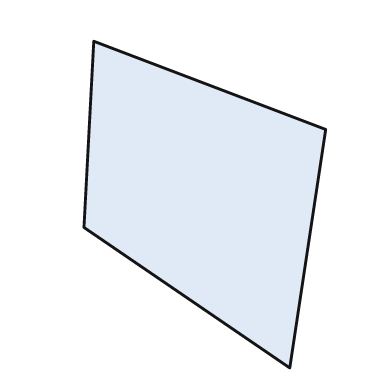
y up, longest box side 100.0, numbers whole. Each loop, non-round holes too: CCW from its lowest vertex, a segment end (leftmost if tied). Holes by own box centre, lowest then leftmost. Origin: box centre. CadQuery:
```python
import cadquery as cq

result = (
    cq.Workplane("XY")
    .moveTo(26.0, -50.0)
    .lineTo(37.0, 23.0)
    .lineTo(-34.0, 50.0)
    .lineTo(-37.0, -7.0)
    .close()
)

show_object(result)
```